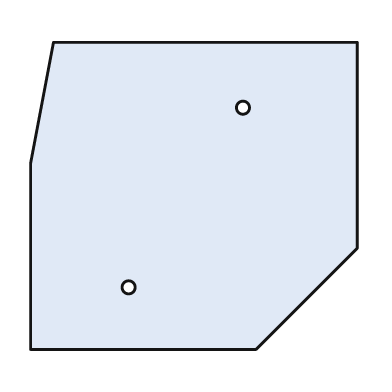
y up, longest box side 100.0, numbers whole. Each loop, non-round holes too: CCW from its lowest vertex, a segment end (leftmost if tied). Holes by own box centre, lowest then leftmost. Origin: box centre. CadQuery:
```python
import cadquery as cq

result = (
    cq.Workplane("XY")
    .moveTo(-50.0, -47.0)
    .lineTo(19.0, -47.0)
    .lineTo(50.0, -16.0)
    .lineTo(50.0, 47.0)
    .lineTo(-43.0, 47.0)
    .lineTo(-50.0, 10.0)
    .close()
    .moveTo(-20.0, -28.0)
    .circle(2.0)
    .moveTo(15.0, 27.0)
    .circle(2.0)
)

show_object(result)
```